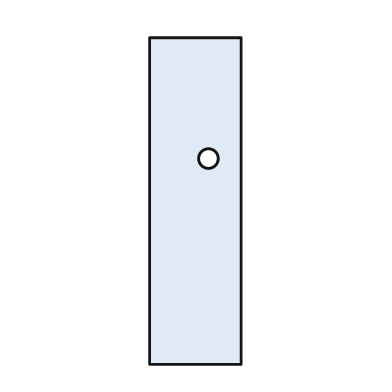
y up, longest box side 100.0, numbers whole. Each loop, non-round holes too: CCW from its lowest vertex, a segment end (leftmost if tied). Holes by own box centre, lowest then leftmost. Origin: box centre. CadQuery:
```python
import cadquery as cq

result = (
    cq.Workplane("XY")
    .moveTo(-14.0, -50.0)
    .lineTo(14.0, -50.0)
    .lineTo(14.0, 50.0)
    .lineTo(-14.0, 50.0)
    .close()
    .moveTo(4.0, 13.0)
    .circle(3.0)
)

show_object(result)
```